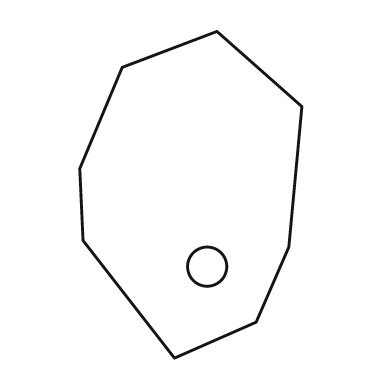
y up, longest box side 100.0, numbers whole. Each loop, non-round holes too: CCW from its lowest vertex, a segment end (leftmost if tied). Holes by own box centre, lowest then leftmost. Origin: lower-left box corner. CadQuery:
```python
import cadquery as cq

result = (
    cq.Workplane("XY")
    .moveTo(29.0, 0.0)
    .lineTo(54.0, 11.0)
    .lineTo(64.0, 34.0)
    .lineTo(68.0, 77.0)
    .lineTo(42.0, 100.0)
    .lineTo(13.0, 89.0)
    .lineTo(0.0, 58.0)
    .lineTo(1.0, 36.0)
    .close()
    .moveTo(39.0, 28.0)
    .circle(6.0)
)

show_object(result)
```